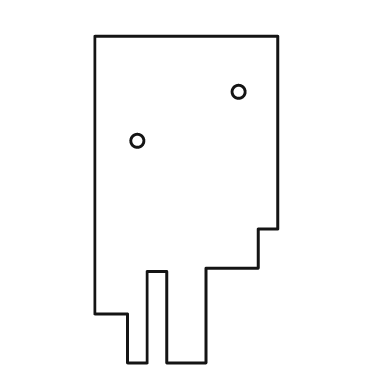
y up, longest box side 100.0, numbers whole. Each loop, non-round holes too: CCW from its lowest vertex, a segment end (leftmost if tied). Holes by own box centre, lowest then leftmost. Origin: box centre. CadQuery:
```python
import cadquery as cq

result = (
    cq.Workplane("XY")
    .moveTo(-18.0, -50.0)
    .lineTo(-12.0, -50.0)
    .lineTo(-12.0, -22.0)
    .lineTo(-6.0, -22.0)
    .lineTo(-6.0, -50.0)
    .lineTo(6.0, -50.0)
    .lineTo(6.0, -21.0)
    .lineTo(22.0, -21.0)
    .lineTo(22.0, -9.0)
    .lineTo(28.0, -9.0)
    .lineTo(28.0, 50.0)
    .lineTo(-28.0, 50.0)
    .lineTo(-28.0, -35.0)
    .lineTo(-18.0, -35.0)
    .close()
    .moveTo(-15.0, 18.0)
    .circle(2.0)
    .moveTo(16.0, 33.0)
    .circle(2.0)
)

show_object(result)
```